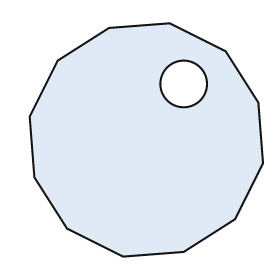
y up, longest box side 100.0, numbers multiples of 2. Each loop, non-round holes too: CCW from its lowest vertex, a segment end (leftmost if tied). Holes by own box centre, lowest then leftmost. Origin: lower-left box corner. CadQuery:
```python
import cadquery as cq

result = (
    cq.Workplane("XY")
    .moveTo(40.0, 0.0)
    .lineTo(66.0, 2.0)
    .lineTo(88.0, 16.0)
    .lineTo(100.0, 40.0)
    .lineTo(98.0, 66.0)
    .lineTo(84.0, 88.0)
    .lineTo(60.0, 100.0)
    .lineTo(34.0, 98.0)
    .lineTo(12.0, 84.0)
    .lineTo(0.0, 60.0)
    .lineTo(2.0, 34.0)
    .lineTo(16.0, 12.0)
    .close()
    .moveTo(66.0, 74.0)
    .circle(10.0)
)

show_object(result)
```